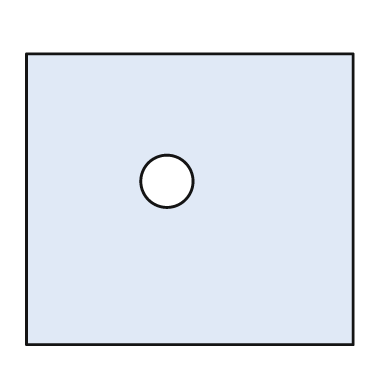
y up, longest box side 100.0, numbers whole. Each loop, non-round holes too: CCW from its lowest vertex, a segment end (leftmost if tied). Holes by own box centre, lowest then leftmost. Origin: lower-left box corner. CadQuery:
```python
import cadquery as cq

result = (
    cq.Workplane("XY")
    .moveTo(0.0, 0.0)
    .lineTo(100.0, 0.0)
    .lineTo(100.0, 89.0)
    .lineTo(0.0, 89.0)
    .close()
    .moveTo(43.0, 50.0)
    .circle(8.0)
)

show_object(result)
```